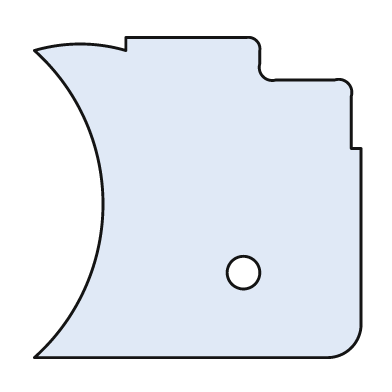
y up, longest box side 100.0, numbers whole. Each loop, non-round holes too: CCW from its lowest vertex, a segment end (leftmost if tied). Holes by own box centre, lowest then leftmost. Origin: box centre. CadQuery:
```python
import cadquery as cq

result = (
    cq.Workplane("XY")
    .moveTo(-50.0, -49.0)
    .lineTo(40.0, -49.0)
    .threePointArc((47.0, -46.0), (50.0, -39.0))
    .lineTo(50.0, 15.0)
    .lineTo(47.0, 15.0)
    .lineTo(47.0, 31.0)
    .threePointArc((46.0, 35.0), (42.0, 36.0))
    .lineTo(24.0, 36.0)
    .threePointArc((20.0, 37.0), (19.0, 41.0))
    .lineTo(19.0, 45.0)
    .threePointArc((18.0, 48.0), (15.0, 49.0))
    .lineTo(-22.0, 49.0)
    .lineTo(-22.0, 45.0)
    .threePointArc((-36.0, 47.0), (-50.0, 45.0))
    .threePointArc((-29.0, -2.0), (-50.0, -49.0))
    .close()
    .moveTo(14.0, -23.0)
    .circle(5.0)
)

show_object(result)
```